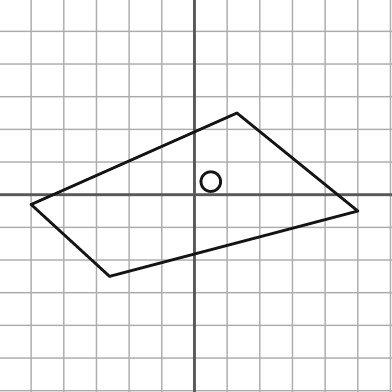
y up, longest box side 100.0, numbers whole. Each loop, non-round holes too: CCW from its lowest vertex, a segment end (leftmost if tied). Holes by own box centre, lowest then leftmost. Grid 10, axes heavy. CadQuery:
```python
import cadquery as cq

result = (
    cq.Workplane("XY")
    .moveTo(-26.0, -25.0)
    .lineTo(50.0, -5.0)
    .lineTo(13.0, 25.0)
    .lineTo(-50.0, -3.0)
    .close()
    .moveTo(5.0, 4.0)
    .circle(3.0)
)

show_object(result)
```